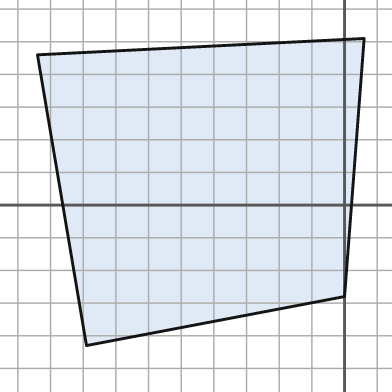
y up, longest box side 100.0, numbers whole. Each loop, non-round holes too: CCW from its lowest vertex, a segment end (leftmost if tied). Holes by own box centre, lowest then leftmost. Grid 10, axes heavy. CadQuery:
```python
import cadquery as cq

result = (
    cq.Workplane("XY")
    .moveTo(-79.0, -43.0)
    .lineTo(0.0, -28.0)
    .lineTo(6.0, 51.0)
    .lineTo(-94.0, 46.0)
    .close()
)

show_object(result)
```